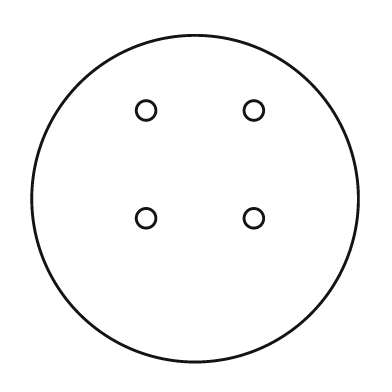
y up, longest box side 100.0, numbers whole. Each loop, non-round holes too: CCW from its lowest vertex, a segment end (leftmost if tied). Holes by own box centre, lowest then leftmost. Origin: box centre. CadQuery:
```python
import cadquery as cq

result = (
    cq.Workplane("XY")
    .moveTo(0.0, 0.0)
    .circle(50.0)
    .moveTo(-15.0, -6.0)
    .circle(3.0)
    .moveTo(18.0, -6.0)
    .circle(3.0)
    .moveTo(-15.0, 27.0)
    .circle(3.0)
    .moveTo(18.0, 27.0)
    .circle(3.0)
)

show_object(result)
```